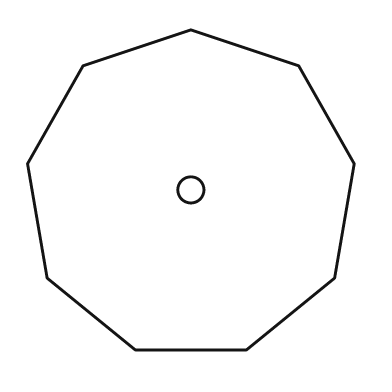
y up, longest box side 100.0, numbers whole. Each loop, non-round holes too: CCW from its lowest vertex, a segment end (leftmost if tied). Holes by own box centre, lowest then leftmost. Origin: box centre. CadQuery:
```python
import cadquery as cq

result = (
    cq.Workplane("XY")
    .moveTo(-17.0, -49.0)
    .lineTo(17.0, -49.0)
    .lineTo(44.0, -27.0)
    .lineTo(50.0, 8.0)
    .lineTo(33.0, 38.0)
    .lineTo(0.0, 49.0)
    .lineTo(-33.0, 38.0)
    .lineTo(-50.0, 8.0)
    .lineTo(-44.0, -27.0)
    .close()
    .moveTo(0.0, 0.0)
    .circle(4.0)
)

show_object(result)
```